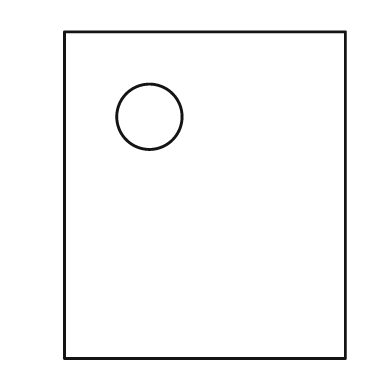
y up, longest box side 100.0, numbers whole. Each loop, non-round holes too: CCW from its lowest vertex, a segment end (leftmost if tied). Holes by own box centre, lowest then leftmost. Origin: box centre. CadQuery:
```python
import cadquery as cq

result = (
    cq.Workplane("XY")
    .moveTo(-43.0, -50.0)
    .lineTo(43.0, -50.0)
    .lineTo(43.0, 50.0)
    .lineTo(-43.0, 50.0)
    .close()
    .moveTo(-17.0, 24.0)
    .circle(10.0)
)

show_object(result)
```